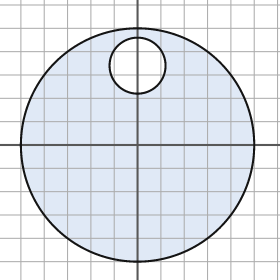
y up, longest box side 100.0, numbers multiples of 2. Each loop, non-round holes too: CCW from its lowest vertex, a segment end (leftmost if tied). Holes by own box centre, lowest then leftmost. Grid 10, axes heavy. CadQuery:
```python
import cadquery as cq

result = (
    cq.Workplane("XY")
    .moveTo(0.0, 0.0)
    .circle(50.0)
    .moveTo(0.0, 34.0)
    .circle(12.0)
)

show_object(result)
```